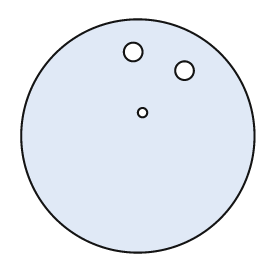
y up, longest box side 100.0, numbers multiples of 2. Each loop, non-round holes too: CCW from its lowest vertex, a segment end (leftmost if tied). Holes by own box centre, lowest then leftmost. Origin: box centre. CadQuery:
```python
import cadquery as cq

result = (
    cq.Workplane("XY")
    .moveTo(0.0, 0.0)
    .circle(50.0)
    .moveTo(2.0, 10.0)
    .circle(2.0)
    .moveTo(20.0, 28.0)
    .circle(4.0)
    .moveTo(-2.0, 36.0)
    .circle(4.0)
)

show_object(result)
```